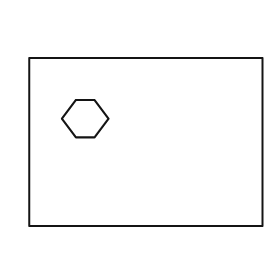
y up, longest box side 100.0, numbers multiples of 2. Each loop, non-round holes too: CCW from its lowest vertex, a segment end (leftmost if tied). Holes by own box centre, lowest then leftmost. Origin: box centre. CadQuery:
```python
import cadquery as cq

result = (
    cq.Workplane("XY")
    .moveTo(-50.0, -36.0)
    .lineTo(50.0, -36.0)
    .lineTo(50.0, 36.0)
    .lineTo(-50.0, 36.0)
    .close()
    .moveTo(-30.0, 2.0)
    .lineTo(-22.0, 2.0)
    .lineTo(-16.0, 10.0)
    .lineTo(-22.0, 18.0)
    .lineTo(-30.0, 18.0)
    .lineTo(-36.0, 10.0)
    .close()
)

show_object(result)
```